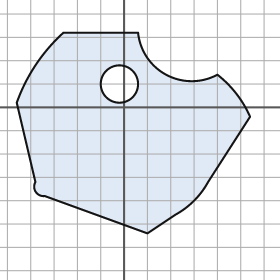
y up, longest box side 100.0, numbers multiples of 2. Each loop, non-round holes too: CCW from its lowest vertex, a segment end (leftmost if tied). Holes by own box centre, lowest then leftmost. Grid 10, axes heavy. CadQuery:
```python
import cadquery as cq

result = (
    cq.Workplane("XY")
    .moveTo(10.0, -54.0)
    .lineTo(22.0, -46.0)
    .threePointArc((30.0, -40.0), (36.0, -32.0))
    .lineTo(54.0, -4.0)
    .threePointArc((48.0, 6.0), (40.0, 14.0))
    .threePointArc((18.0, 14.0), (6.0, 32.0))
    .lineTo(-26.0, 32.0)
    .threePointArc((-38.0, 18.0), (-46.0, 2.0))
    .lineTo(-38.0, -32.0)
    .threePointArc((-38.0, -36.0), (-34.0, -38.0))
    .close()
    .moveTo(-2.0, 10.0)
    .circle(8.0)
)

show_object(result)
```